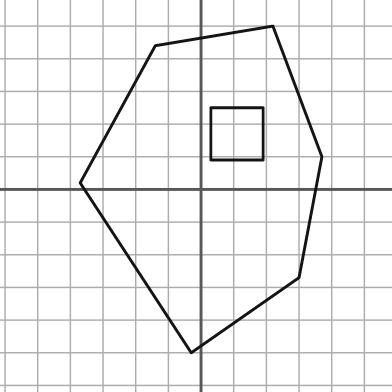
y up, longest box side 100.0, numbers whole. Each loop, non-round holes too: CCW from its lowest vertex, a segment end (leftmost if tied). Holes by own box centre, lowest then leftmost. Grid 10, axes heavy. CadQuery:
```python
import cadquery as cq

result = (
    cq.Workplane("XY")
    .moveTo(-3.0, -50.0)
    .lineTo(30.0, -27.0)
    .lineTo(37.0, 10.0)
    .lineTo(22.0, 50.0)
    .lineTo(-14.0, 44.0)
    .lineTo(-37.0, 2.0)
    .close()
    .moveTo(3.0, 9.0)
    .lineTo(19.0, 9.0)
    .lineTo(19.0, 25.0)
    .lineTo(3.0, 25.0)
    .close()
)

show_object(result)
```